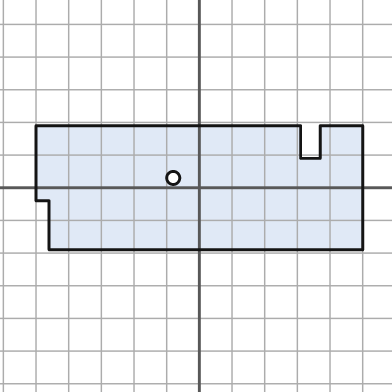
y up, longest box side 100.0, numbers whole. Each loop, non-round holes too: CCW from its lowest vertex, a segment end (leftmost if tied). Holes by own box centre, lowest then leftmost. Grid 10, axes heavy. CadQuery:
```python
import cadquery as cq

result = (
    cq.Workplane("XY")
    .moveTo(-46.0, -19.0)
    .lineTo(50.0, -19.0)
    .lineTo(50.0, 19.0)
    .lineTo(37.0, 19.0)
    .lineTo(37.0, 9.0)
    .lineTo(31.0, 9.0)
    .lineTo(31.0, 19.0)
    .lineTo(-50.0, 19.0)
    .lineTo(-50.0, -4.0)
    .lineTo(-46.0, -4.0)
    .close()
    .moveTo(-8.0, 3.0)
    .circle(2.0)
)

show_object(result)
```